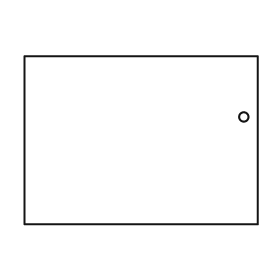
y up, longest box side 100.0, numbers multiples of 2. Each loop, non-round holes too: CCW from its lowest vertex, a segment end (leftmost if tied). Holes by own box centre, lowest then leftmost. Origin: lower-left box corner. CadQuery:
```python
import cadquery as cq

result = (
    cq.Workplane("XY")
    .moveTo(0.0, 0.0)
    .lineTo(100.0, 0.0)
    .lineTo(100.0, 72.0)
    .lineTo(0.0, 72.0)
    .close()
    .moveTo(94.0, 46.0)
    .circle(2.0)
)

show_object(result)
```